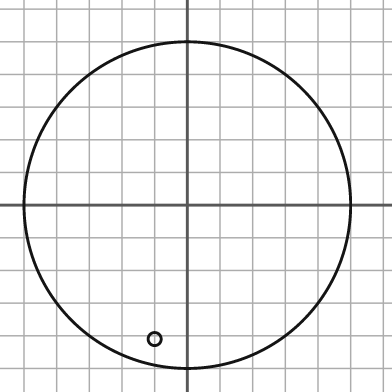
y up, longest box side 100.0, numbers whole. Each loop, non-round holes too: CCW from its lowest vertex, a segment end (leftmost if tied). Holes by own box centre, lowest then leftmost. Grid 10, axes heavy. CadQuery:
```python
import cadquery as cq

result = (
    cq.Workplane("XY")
    .moveTo(0.0, 0.0)
    .circle(50.0)
    .moveTo(-10.0, -41.0)
    .circle(2.0)
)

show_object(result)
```